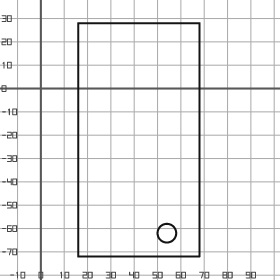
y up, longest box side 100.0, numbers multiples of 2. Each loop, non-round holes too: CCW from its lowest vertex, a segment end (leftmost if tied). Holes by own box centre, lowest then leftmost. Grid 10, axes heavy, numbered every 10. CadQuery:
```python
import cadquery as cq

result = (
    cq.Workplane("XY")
    .moveTo(16.0, -72.0)
    .lineTo(68.0, -72.0)
    .lineTo(68.0, 28.0)
    .lineTo(16.0, 28.0)
    .close()
    .moveTo(54.0, -62.0)
    .circle(4.0)
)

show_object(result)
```